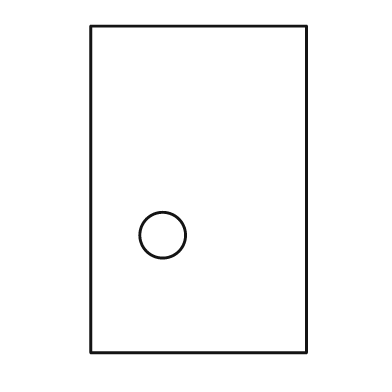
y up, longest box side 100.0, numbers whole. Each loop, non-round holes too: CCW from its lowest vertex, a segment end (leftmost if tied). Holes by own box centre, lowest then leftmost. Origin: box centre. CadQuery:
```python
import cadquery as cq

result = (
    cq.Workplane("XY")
    .moveTo(-33.0, -50.0)
    .lineTo(33.0, -50.0)
    .lineTo(33.0, 50.0)
    .lineTo(-33.0, 50.0)
    .close()
    .moveTo(-11.0, -14.0)
    .circle(7.0)
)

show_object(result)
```